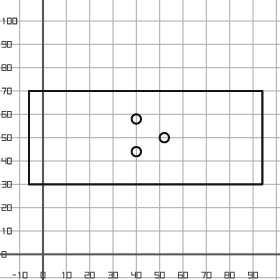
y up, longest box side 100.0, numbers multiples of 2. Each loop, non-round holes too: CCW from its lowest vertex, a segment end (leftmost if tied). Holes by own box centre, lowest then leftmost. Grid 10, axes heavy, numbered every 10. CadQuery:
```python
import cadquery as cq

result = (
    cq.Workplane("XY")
    .moveTo(-6.0, 30.0)
    .lineTo(94.0, 30.0)
    .lineTo(94.0, 70.0)
    .lineTo(-6.0, 70.0)
    .close()
    .moveTo(40.0, 44.0)
    .circle(2.0)
    .moveTo(52.0, 50.0)
    .circle(2.0)
    .moveTo(40.0, 58.0)
    .circle(2.0)
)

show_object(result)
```